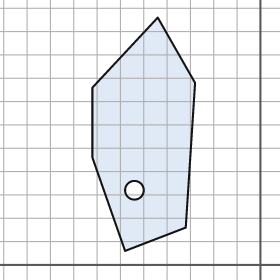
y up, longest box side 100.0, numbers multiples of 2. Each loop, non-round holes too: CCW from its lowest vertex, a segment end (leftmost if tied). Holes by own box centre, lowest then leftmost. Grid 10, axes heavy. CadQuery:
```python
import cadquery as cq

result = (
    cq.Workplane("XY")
    .moveTo(-58.0, 6.0)
    .lineTo(-32.0, 16.0)
    .lineTo(-28.0, 78.0)
    .lineTo(-44.0, 106.0)
    .lineTo(-72.0, 76.0)
    .lineTo(-72.0, 46.0)
    .close()
    .moveTo(-54.0, 32.0)
    .circle(4.0)
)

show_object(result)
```